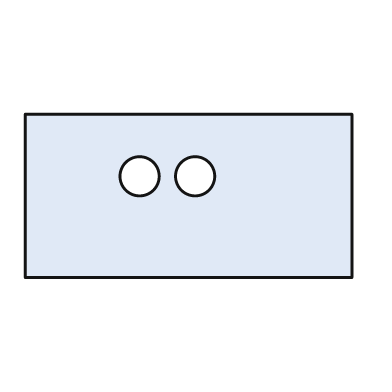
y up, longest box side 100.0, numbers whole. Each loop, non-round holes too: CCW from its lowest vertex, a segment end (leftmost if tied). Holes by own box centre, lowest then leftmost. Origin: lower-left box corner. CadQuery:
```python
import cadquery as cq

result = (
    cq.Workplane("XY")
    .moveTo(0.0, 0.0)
    .lineTo(100.0, 0.0)
    .lineTo(100.0, 50.0)
    .lineTo(0.0, 50.0)
    .close()
    .moveTo(35.0, 31.0)
    .circle(6.0)
    .moveTo(52.0, 31.0)
    .circle(6.0)
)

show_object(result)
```